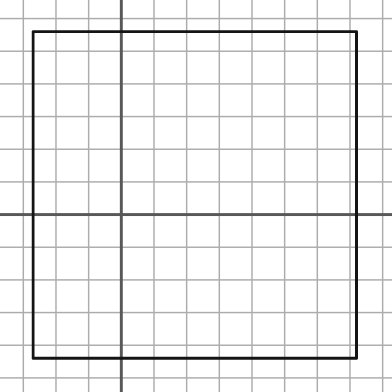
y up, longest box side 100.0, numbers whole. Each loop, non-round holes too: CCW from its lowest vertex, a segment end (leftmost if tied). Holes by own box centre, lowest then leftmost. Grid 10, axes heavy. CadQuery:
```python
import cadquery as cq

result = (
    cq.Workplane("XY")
    .moveTo(-27.0, -44.0)
    .lineTo(72.0, -44.0)
    .lineTo(72.0, 56.0)
    .lineTo(-27.0, 56.0)
    .close()
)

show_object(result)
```